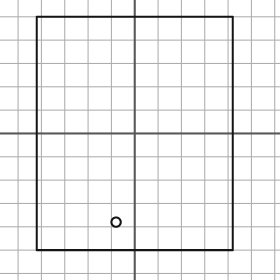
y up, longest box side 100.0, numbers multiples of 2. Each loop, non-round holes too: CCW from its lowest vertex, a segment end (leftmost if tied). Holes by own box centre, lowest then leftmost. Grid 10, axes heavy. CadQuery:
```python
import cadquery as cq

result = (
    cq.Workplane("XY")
    .moveTo(-42.0, -50.0)
    .lineTo(42.0, -50.0)
    .lineTo(42.0, 50.0)
    .lineTo(-42.0, 50.0)
    .close()
    .moveTo(-8.0, -38.0)
    .circle(2.0)
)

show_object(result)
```